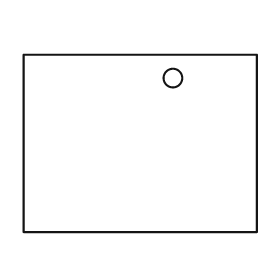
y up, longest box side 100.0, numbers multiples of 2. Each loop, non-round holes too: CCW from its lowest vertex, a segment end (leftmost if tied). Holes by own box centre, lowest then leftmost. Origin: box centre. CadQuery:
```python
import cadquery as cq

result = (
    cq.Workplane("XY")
    .moveTo(-50.0, -38.0)
    .lineTo(50.0, -38.0)
    .lineTo(50.0, 38.0)
    .lineTo(-50.0, 38.0)
    .close()
    .moveTo(14.0, 28.0)
    .circle(4.0)
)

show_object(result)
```